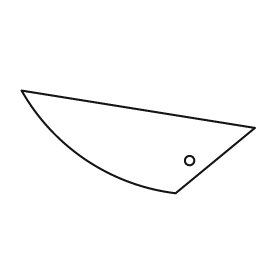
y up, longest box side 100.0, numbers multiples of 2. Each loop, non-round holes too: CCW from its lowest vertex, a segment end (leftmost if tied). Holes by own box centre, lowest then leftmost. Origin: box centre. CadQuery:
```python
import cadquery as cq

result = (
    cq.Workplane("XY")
    .moveTo(16.0, -22.0)
    .lineTo(50.0, 6.0)
    .lineTo(-50.0, 22.0)
    .threePointArc((-22.0, -8.0), (16.0, -22.0))
    .close()
    .moveTo(22.0, -8.0)
    .circle(2.0)
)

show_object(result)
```